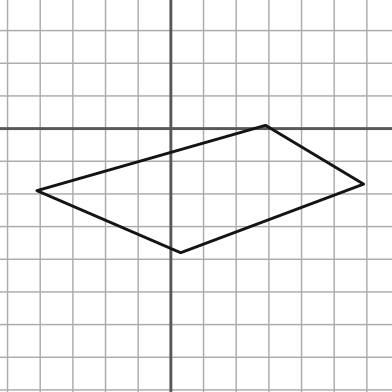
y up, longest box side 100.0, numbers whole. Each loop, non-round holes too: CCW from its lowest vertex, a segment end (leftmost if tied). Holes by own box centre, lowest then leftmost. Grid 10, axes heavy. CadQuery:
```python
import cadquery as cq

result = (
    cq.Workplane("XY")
    .moveTo(3.0, -38.0)
    .lineTo(59.0, -17.0)
    .lineTo(29.0, 1.0)
    .lineTo(-41.0, -19.0)
    .close()
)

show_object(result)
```